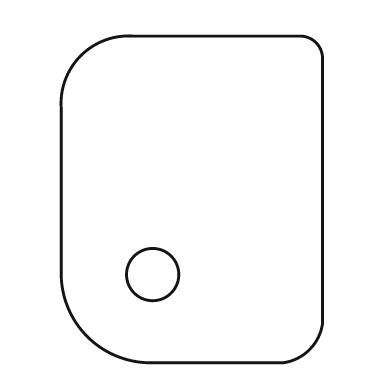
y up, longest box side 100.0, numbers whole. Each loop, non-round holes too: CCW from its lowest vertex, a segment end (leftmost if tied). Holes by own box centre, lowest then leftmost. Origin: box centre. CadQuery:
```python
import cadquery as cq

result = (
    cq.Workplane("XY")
    .moveTo(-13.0, -50.0)
    .lineTo(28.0, -50.0)
    .threePointArc((36.0, -46.0), (40.0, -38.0))
    .lineTo(40.0, 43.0)
    .threePointArc((38.0, 48.0), (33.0, 50.0))
    .lineTo(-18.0, 50.0)
    .threePointArc((-34.0, 44.0), (-40.0, 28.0))
    .lineTo(-40.0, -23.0)
    .threePointArc((-32.0, -42.0), (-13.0, -50.0))
    .close()
    .moveTo(-12.0, -23.0)
    .circle(8.0)
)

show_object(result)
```